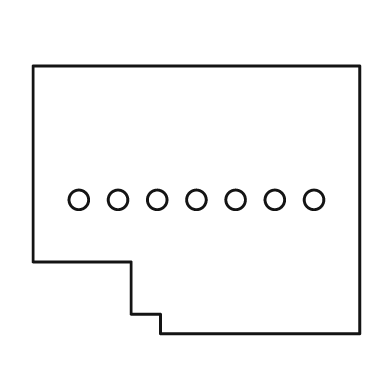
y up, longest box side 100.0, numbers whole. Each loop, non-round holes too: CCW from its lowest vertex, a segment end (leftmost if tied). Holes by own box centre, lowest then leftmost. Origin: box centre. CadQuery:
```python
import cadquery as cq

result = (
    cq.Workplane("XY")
    .moveTo(-11.0, -41.0)
    .lineTo(50.0, -41.0)
    .lineTo(50.0, 41.0)
    .lineTo(-50.0, 41.0)
    .lineTo(-50.0, -19.0)
    .lineTo(-20.0, -19.0)
    .lineTo(-20.0, -35.0)
    .lineTo(-11.0, -35.0)
    .close()
    .moveTo(-36.0, 0.0)
    .circle(3.0)
    .moveTo(-24.0, 0.0)
    .circle(3.0)
    .moveTo(-12.0, 0.0)
    .circle(3.0)
    .moveTo(0.0, 0.0)
    .circle(3.0)
    .moveTo(12.0, 0.0)
    .circle(3.0)
    .moveTo(24.0, 0.0)
    .circle(3.0)
    .moveTo(36.0, 0.0)
    .circle(3.0)
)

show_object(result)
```